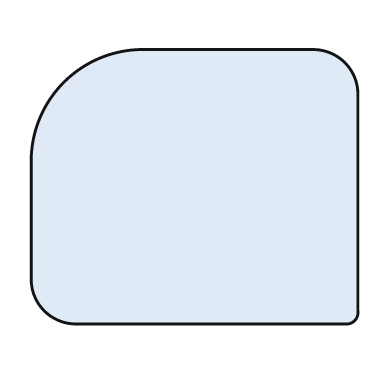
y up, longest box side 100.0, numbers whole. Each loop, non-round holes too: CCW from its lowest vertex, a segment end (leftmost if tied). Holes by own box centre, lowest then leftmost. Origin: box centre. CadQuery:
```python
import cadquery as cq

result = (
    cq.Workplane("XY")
    .moveTo(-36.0, -42.0)
    .lineTo(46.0, -42.0)
    .threePointArc((49.0, -41.0), (50.0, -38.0))
    .lineTo(50.0, 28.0)
    .threePointArc((46.0, 38.0), (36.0, 42.0))
    .lineTo(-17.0, 42.0)
    .threePointArc((-40.0, 32.0), (-50.0, 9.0))
    .lineTo(-50.0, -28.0)
    .threePointArc((-46.0, -38.0), (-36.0, -42.0))
    .close()
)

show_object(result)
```